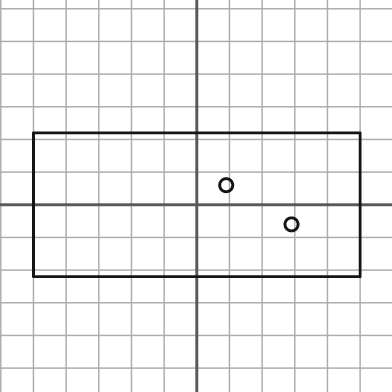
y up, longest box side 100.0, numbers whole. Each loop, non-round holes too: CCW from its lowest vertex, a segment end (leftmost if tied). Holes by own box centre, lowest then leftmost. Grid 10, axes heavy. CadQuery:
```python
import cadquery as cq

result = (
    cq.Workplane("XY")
    .moveTo(-50.0, -22.0)
    .lineTo(50.0, -22.0)
    .lineTo(50.0, 22.0)
    .lineTo(-50.0, 22.0)
    .close()
    .moveTo(29.0, -6.0)
    .circle(2.0)
    .moveTo(9.0, 6.0)
    .circle(2.0)
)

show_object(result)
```